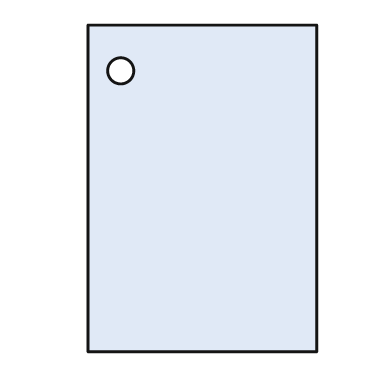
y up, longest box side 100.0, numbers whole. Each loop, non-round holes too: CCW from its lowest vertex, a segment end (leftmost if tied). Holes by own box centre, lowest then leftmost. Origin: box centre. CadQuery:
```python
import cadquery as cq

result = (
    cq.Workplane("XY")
    .moveTo(-35.0, -50.0)
    .lineTo(35.0, -50.0)
    .lineTo(35.0, 50.0)
    .lineTo(-35.0, 50.0)
    .close()
    .moveTo(-25.0, 36.0)
    .circle(4.0)
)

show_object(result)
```